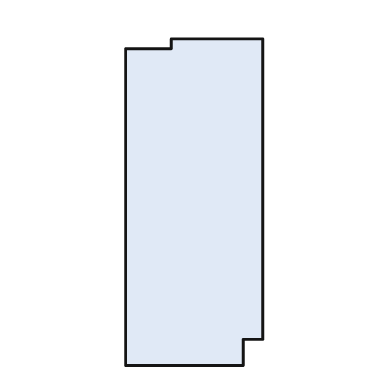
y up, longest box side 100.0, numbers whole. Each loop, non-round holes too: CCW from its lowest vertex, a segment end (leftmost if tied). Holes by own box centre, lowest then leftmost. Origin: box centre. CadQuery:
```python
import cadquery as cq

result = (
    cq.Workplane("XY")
    .moveTo(-21.0, -50.0)
    .lineTo(15.0, -50.0)
    .lineTo(15.0, -42.0)
    .lineTo(21.0, -42.0)
    .lineTo(21.0, 50.0)
    .lineTo(-7.0, 50.0)
    .lineTo(-7.0, 47.0)
    .lineTo(-21.0, 47.0)
    .close()
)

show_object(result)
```